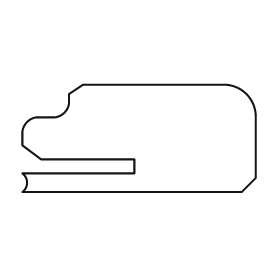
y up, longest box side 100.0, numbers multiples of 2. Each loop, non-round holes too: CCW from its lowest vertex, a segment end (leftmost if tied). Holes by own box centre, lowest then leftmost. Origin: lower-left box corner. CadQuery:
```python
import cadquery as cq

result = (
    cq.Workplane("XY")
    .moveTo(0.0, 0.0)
    .lineTo(94.0, 0.0)
    .lineTo(100.0, 6.0)
    .lineTo(100.0, 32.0)
    .threePointArc((96.0, 42.0), (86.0, 46.0))
    .lineTo(26.0, 46.0)
    .lineTo(20.0, 42.0)
    .lineTo(20.0, 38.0)
    .threePointArc((18.0, 34.0), (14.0, 32.0))
    .lineTo(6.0, 32.0)
    .threePointArc((2.0, 30.0), (0.0, 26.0))
    .lineTo(0.0, 20.0)
    .lineTo(8.0, 14.0)
    .lineTo(48.0, 14.0)
    .lineTo(48.0, 8.0)
    .lineTo(0.0, 8.0)
    .threePointArc((2.0, 4.0), (0.0, 0.0))
    .close()
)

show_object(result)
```